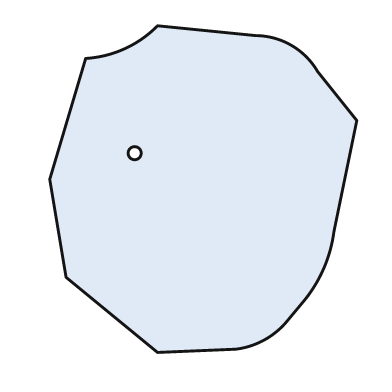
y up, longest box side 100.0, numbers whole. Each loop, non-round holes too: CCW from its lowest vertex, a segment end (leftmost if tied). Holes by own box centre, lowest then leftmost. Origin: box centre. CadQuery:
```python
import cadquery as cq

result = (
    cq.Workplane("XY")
    .moveTo(-14.0, -50.0)
    .lineTo(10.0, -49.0)
    .threePointArc((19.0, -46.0), (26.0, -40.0))
    .lineTo(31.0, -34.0)
    .threePointArc((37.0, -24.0), (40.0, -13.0))
    .lineTo(47.0, 21.0)
    .lineTo(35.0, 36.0)
    .threePointArc((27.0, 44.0), (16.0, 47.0))
    .lineTo(-14.0, 50.0)
    .threePointArc((-24.0, 43.0), (-36.0, 40.0))
    .lineTo(-47.0, 3.0)
    .lineTo(-42.0, -27.0)
    .close()
    .moveTo(-21.0, 11.0)
    .circle(2.0)
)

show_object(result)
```